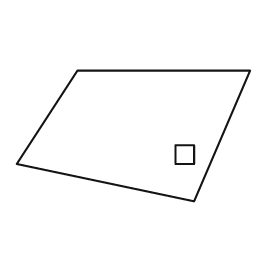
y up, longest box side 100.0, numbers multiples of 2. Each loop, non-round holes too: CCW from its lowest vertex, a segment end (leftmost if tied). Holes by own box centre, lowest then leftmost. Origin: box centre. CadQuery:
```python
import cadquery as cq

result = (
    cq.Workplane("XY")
    .moveTo(26.0, -28.0)
    .lineTo(50.0, 28.0)
    .lineTo(-24.0, 28.0)
    .lineTo(-50.0, -12.0)
    .close()
    .moveTo(18.0, -12.0)
    .lineTo(26.0, -12.0)
    .lineTo(26.0, -4.0)
    .lineTo(18.0, -4.0)
    .close()
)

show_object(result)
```